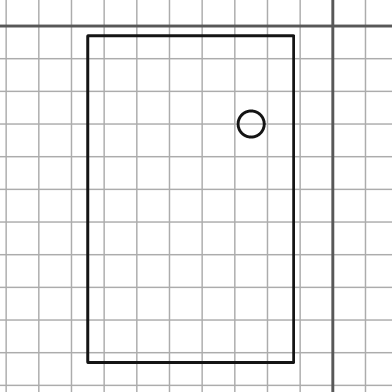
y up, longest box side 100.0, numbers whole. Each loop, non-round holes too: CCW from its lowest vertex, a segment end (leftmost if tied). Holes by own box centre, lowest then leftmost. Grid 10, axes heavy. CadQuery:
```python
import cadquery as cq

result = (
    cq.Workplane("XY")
    .moveTo(-75.0, -103.0)
    .lineTo(-12.0, -103.0)
    .lineTo(-12.0, -3.0)
    .lineTo(-75.0, -3.0)
    .close()
    .moveTo(-25.0, -30.0)
    .circle(4.0)
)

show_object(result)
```